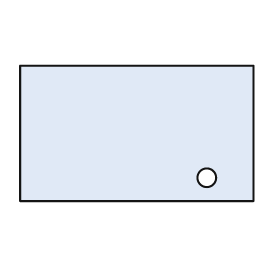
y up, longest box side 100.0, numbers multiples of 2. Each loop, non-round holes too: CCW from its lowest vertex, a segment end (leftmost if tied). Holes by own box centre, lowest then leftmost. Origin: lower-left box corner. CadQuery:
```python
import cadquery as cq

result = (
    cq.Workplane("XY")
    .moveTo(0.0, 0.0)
    .lineTo(100.0, 0.0)
    .lineTo(100.0, 58.0)
    .lineTo(0.0, 58.0)
    .close()
    .moveTo(80.0, 10.0)
    .circle(4.0)
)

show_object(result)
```